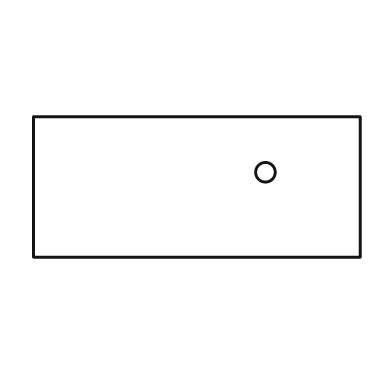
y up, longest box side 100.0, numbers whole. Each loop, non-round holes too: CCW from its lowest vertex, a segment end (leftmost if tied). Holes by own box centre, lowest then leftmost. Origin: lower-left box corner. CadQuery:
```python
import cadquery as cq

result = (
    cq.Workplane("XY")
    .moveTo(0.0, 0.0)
    .lineTo(100.0, 0.0)
    .lineTo(100.0, 43.0)
    .lineTo(0.0, 43.0)
    .close()
    .moveTo(71.0, 26.0)
    .circle(3.0)
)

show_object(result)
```